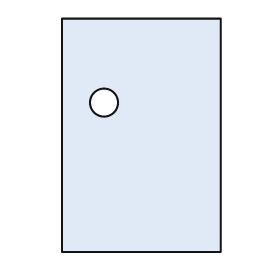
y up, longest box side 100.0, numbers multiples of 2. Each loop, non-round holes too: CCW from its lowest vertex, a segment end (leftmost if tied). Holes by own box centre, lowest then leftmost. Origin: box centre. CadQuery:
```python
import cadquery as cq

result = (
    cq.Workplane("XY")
    .moveTo(-34.0, -50.0)
    .lineTo(34.0, -50.0)
    .lineTo(34.0, 50.0)
    .lineTo(-34.0, 50.0)
    .close()
    .moveTo(-16.0, 14.0)
    .circle(6.0)
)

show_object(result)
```